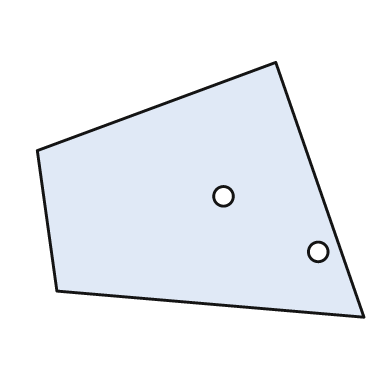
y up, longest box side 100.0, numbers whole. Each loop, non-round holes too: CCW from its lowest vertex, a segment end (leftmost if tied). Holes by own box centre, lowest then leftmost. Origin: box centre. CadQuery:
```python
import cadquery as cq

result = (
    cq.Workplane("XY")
    .moveTo(50.0, -39.0)
    .lineTo(23.0, 39.0)
    .lineTo(-50.0, 12.0)
    .lineTo(-44.0, -31.0)
    .close()
    .moveTo(36.0, -19.0)
    .circle(3.0)
    .moveTo(7.0, -2.0)
    .circle(3.0)
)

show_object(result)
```